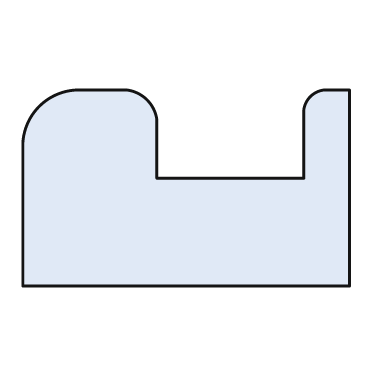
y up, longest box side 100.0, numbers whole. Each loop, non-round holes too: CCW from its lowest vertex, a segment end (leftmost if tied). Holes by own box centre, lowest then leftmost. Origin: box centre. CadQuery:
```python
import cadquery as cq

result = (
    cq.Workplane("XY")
    .moveTo(-50.0, -30.0)
    .lineTo(50.0, -30.0)
    .lineTo(50.0, 30.0)
    .lineTo(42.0, 30.0)
    .threePointArc((38.0, 28.0), (36.0, 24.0))
    .lineTo(36.0, 3.0)
    .lineTo(-9.0, 3.0)
    .lineTo(-9.0, 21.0)
    .threePointArc((-12.0, 27.0), (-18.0, 30.0))
    .lineTo(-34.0, 30.0)
    .threePointArc((-45.0, 25.0), (-50.0, 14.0))
    .close()
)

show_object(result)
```